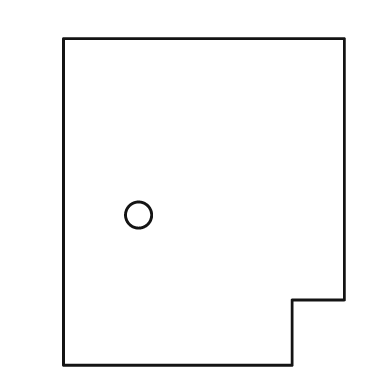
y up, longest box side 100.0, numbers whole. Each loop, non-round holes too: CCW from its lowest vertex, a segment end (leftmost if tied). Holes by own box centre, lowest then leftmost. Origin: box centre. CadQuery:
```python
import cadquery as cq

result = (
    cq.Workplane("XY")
    .moveTo(-43.0, -50.0)
    .lineTo(27.0, -50.0)
    .lineTo(27.0, -30.0)
    .lineTo(43.0, -30.0)
    .lineTo(43.0, 50.0)
    .lineTo(-43.0, 50.0)
    .close()
    .moveTo(-20.0, -4.0)
    .circle(4.0)
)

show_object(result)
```